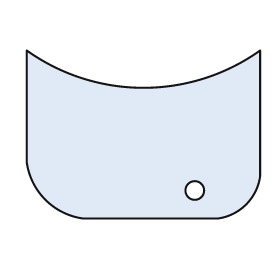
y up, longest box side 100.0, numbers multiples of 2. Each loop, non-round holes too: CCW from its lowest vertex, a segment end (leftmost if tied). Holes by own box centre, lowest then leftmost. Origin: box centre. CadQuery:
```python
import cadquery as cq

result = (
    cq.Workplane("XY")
    .moveTo(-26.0, -36.0)
    .lineTo(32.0, -36.0)
    .threePointArc((44.0, -30.0), (50.0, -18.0))
    .lineTo(50.0, 36.0)
    .threePointArc((0.0, 20.0), (-50.0, 36.0))
    .lineTo(-50.0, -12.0)
    .threePointArc((-42.0, -28.0), (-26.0, -36.0))
    .close()
    .moveTo(22.0, -24.0)
    .circle(4.0)
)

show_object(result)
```